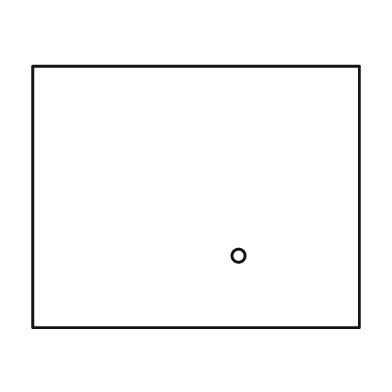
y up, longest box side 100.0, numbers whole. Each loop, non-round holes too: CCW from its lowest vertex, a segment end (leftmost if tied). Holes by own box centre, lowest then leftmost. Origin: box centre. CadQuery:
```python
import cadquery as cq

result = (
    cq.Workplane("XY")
    .moveTo(-50.0, -40.0)
    .lineTo(50.0, -40.0)
    .lineTo(50.0, 40.0)
    .lineTo(-50.0, 40.0)
    .close()
    .moveTo(13.0, -18.0)
    .circle(2.0)
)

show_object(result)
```